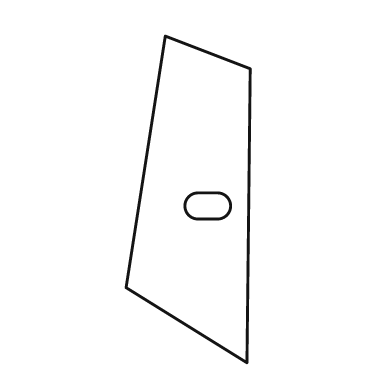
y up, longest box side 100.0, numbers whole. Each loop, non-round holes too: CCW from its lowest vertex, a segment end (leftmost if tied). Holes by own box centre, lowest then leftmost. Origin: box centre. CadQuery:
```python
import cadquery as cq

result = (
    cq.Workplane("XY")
    .moveTo(18.0, -50.0)
    .lineTo(19.0, 40.0)
    .lineTo(-7.0, 50.0)
    .lineTo(-19.0, -27.0)
    .close()
    .moveTo(3.0, -6.0)
    .lineTo(9.0, -6.0)
    .threePointArc((13.0, -2.0), (9.0, 2.0))
    .lineTo(3.0, 2.0)
    .threePointArc((-1.0, -2.0), (3.0, -6.0))
    .close()
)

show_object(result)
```